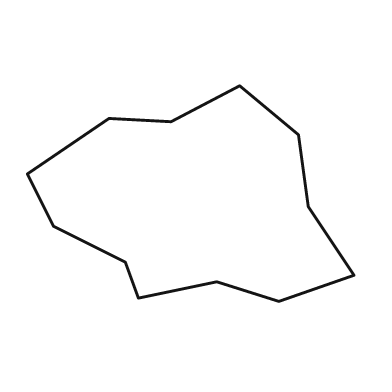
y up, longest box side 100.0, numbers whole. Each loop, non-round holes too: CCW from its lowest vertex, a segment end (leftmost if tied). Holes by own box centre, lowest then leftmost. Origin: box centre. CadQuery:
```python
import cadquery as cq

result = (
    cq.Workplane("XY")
    .moveTo(27.0, -33.0)
    .lineTo(50.0, -25.0)
    .lineTo(36.0, -4.0)
    .lineTo(33.0, 18.0)
    .lineTo(15.0, 33.0)
    .lineTo(-6.0, 22.0)
    .lineTo(-25.0, 23.0)
    .lineTo(-50.0, 6.0)
    .lineTo(-42.0, -10.0)
    .lineTo(-20.0, -21.0)
    .lineTo(-16.0, -32.0)
    .lineTo(8.0, -27.0)
    .close()
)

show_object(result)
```